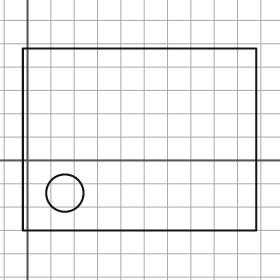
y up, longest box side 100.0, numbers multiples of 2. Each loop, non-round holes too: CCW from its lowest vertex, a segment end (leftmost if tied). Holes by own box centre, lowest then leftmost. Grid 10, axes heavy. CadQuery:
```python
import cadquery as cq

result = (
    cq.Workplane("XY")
    .moveTo(-2.0, -30.0)
    .lineTo(98.0, -30.0)
    .lineTo(98.0, 48.0)
    .lineTo(-2.0, 48.0)
    .close()
    .moveTo(16.0, -14.0)
    .circle(8.0)
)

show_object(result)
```